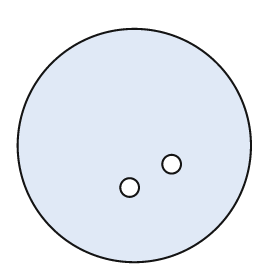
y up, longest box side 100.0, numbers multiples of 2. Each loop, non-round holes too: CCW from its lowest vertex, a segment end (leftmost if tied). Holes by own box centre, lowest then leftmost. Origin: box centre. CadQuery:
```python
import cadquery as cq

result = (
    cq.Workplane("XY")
    .moveTo(0.0, 0.0)
    .circle(50.0)
    .moveTo(-2.0, -18.0)
    .circle(4.0)
    .moveTo(16.0, -8.0)
    .circle(4.0)
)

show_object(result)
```